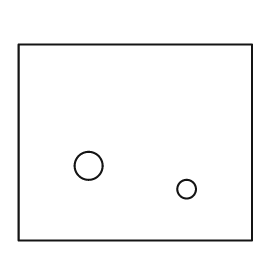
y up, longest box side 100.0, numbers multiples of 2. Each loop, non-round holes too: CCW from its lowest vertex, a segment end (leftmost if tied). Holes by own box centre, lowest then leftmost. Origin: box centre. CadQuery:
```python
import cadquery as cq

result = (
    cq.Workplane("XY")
    .moveTo(-50.0, -42.0)
    .lineTo(50.0, -42.0)
    .lineTo(50.0, 42.0)
    .lineTo(-50.0, 42.0)
    .close()
    .moveTo(22.0, -20.0)
    .circle(4.0)
    .moveTo(-20.0, -10.0)
    .circle(6.0)
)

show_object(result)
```